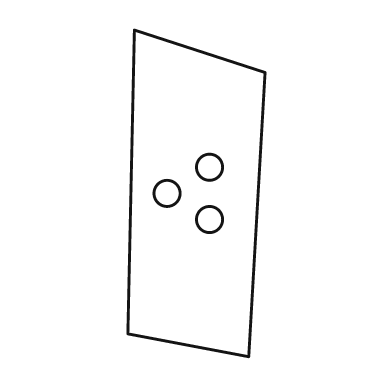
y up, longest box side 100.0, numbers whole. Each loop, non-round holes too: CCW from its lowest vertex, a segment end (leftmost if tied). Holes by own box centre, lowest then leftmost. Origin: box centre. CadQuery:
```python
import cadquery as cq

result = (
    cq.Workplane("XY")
    .moveTo(16.0, -50.0)
    .lineTo(21.0, 37.0)
    .lineTo(-19.0, 50.0)
    .lineTo(-21.0, -43.0)
    .close()
    .moveTo(4.0, -8.0)
    .circle(4.0)
    .moveTo(-9.0, 0.0)
    .circle(4.0)
    .moveTo(4.0, 8.0)
    .circle(4.0)
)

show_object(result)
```